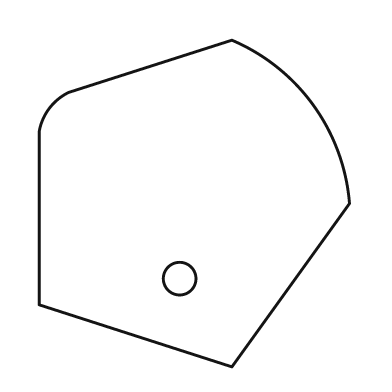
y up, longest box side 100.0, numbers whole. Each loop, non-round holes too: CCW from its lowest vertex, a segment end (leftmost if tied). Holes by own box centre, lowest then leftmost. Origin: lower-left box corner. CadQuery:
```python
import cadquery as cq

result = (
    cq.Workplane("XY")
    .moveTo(59.0, 0.0)
    .lineTo(95.0, 50.0)
    .threePointArc((84.0, 80.0), (59.0, 100.0))
    .lineTo(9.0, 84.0)
    .threePointArc((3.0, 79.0), (0.0, 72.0))
    .lineTo(0.0, 19.0)
    .close()
    .moveTo(43.0, 27.0)
    .circle(5.0)
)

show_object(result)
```